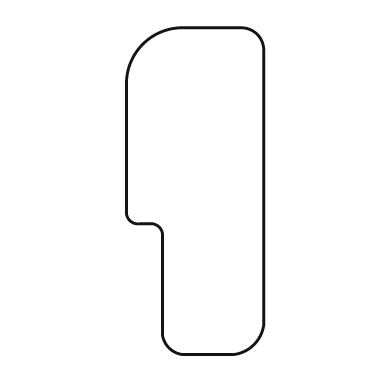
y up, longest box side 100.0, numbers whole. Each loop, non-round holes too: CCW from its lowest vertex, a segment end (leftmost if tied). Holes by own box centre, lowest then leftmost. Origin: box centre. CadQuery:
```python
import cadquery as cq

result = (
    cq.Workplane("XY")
    .moveTo(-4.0, -50.0)
    .lineTo(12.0, -50.0)
    .threePointArc((18.0, -47.0), (21.0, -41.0))
    .lineTo(21.0, 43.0)
    .threePointArc((19.0, 48.0), (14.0, 50.0))
    .lineTo(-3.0, 50.0)
    .threePointArc((-16.0, 45.0), (-21.0, 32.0))
    .lineTo(-21.0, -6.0)
    .threePointArc((-20.0, -9.0), (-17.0, -10.0))
    .lineTo(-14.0, -10.0)
    .threePointArc((-11.0, -11.0), (-10.0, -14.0))
    .lineTo(-10.0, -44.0)
    .threePointArc((-8.0, -48.0), (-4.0, -50.0))
    .close()
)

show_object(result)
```